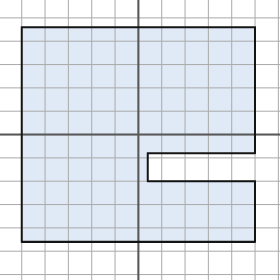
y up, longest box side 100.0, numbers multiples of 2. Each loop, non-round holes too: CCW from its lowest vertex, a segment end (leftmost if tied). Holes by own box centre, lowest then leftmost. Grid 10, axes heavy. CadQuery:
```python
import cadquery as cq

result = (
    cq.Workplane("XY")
    .moveTo(-50.0, -46.0)
    .lineTo(50.0, -46.0)
    .lineTo(50.0, -20.0)
    .lineTo(4.0, -20.0)
    .lineTo(4.0, -8.0)
    .lineTo(50.0, -8.0)
    .lineTo(50.0, 46.0)
    .lineTo(-50.0, 46.0)
    .close()
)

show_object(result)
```